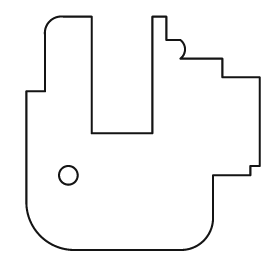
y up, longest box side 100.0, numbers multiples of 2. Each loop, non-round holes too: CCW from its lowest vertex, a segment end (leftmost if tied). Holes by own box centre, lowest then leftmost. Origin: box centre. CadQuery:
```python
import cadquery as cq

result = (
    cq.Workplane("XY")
    .moveTo(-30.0, -50.0)
    .lineTo(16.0, -50.0)
    .threePointArc((26.0, -46.0), (30.0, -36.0))
    .lineTo(30.0, -18.0)
    .lineTo(46.0, -18.0)
    .lineTo(46.0, -14.0)
    .lineTo(50.0, -14.0)
    .lineTo(50.0, 24.0)
    .lineTo(34.0, 24.0)
    .lineTo(34.0, 32.0)
    .lineTo(16.0, 32.0)
    .threePointArc((18.0, 36.0), (16.0, 40.0))
    .lineTo(10.0, 40.0)
    .lineTo(10.0, 50.0)
    .lineTo(4.0, 50.0)
    .lineTo(4.0, 0.0)
    .lineTo(-22.0, 0.0)
    .lineTo(-22.0, 50.0)
    .lineTo(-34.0, 50.0)
    .threePointArc((-40.0, 48.0), (-42.0, 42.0))
    .lineTo(-42.0, 18.0)
    .lineTo(-50.0, 18.0)
    .lineTo(-50.0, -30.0)
    .threePointArc((-44.0, -44.0), (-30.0, -50.0))
    .close()
    .moveTo(-32.0, -18.0)
    .circle(4.0)
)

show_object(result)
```